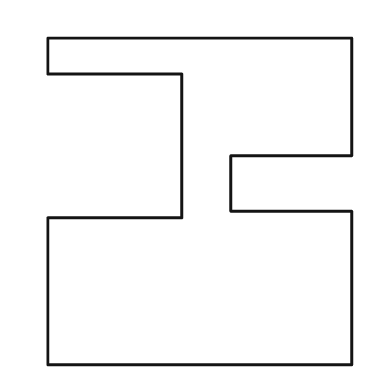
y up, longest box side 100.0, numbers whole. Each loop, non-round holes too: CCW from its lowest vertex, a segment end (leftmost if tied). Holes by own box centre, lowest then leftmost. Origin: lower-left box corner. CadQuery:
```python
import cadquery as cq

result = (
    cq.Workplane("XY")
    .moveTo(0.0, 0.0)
    .lineTo(93.0, 0.0)
    .lineTo(93.0, 47.0)
    .lineTo(56.0, 47.0)
    .lineTo(56.0, 64.0)
    .lineTo(93.0, 64.0)
    .lineTo(93.0, 100.0)
    .lineTo(0.0, 100.0)
    .lineTo(0.0, 89.0)
    .lineTo(41.0, 89.0)
    .lineTo(41.0, 45.0)
    .lineTo(0.0, 45.0)
    .close()
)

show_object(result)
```